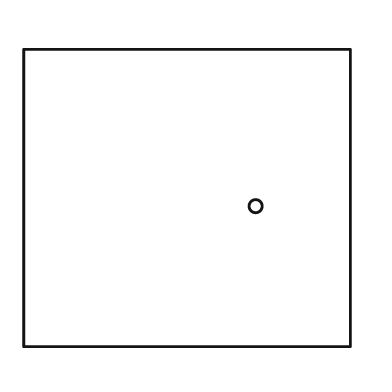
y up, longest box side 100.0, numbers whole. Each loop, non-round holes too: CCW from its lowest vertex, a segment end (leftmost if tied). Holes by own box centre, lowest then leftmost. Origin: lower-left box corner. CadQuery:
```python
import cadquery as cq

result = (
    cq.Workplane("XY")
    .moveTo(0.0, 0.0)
    .lineTo(100.0, 0.0)
    .lineTo(100.0, 91.0)
    .lineTo(0.0, 91.0)
    .close()
    .moveTo(71.0, 43.0)
    .circle(2.0)
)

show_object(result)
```